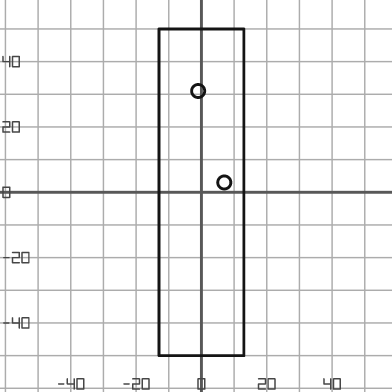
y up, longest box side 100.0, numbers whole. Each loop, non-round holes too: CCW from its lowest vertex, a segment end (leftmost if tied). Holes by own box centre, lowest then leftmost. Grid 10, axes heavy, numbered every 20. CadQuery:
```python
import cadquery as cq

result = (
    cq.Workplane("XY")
    .moveTo(-13.0, -50.0)
    .lineTo(13.0, -50.0)
    .lineTo(13.0, 50.0)
    .lineTo(-13.0, 50.0)
    .close()
    .moveTo(7.0, 3.0)
    .circle(2.0)
    .moveTo(-1.0, 31.0)
    .circle(2.0)
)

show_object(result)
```